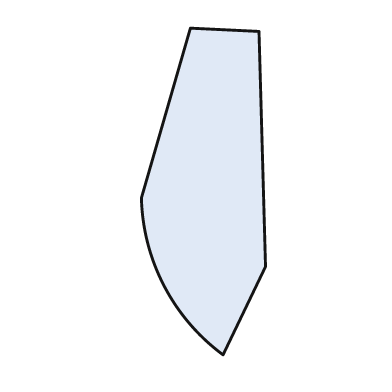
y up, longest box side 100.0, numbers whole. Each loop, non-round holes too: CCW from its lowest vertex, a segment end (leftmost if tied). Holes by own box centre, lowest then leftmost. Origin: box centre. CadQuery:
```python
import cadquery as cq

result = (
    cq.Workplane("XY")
    .moveTo(6.0, -50.0)
    .lineTo(19.0, -23.0)
    .lineTo(17.0, 49.0)
    .lineTo(-4.0, 50.0)
    .lineTo(-19.0, -2.0)
    .threePointArc((-12.0, -29.0), (6.0, -50.0))
    .close()
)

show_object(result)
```